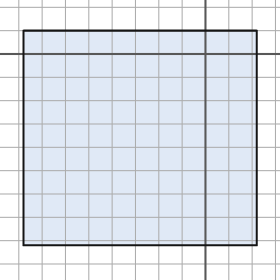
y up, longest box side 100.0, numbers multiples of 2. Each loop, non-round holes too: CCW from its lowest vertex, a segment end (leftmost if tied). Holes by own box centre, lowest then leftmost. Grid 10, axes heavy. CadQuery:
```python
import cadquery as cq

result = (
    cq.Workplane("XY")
    .moveTo(-78.0, -82.0)
    .lineTo(22.0, -82.0)
    .lineTo(22.0, 10.0)
    .lineTo(-78.0, 10.0)
    .close()
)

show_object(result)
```